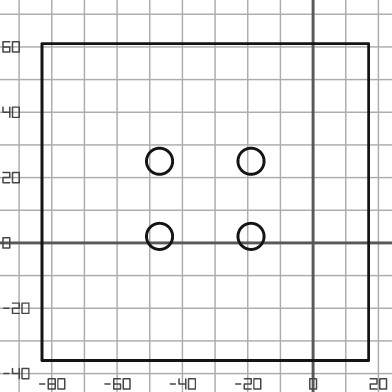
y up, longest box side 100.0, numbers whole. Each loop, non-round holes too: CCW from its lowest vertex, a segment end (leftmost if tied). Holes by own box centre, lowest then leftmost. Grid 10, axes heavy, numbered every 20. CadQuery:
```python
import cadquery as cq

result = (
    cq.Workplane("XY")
    .moveTo(-83.0, -36.0)
    .lineTo(17.0, -36.0)
    .lineTo(17.0, 61.0)
    .lineTo(-83.0, 61.0)
    .close()
    .moveTo(-47.0, 2.0)
    .circle(4.0)
    .moveTo(-19.0, 2.0)
    .circle(4.0)
    .moveTo(-47.0, 25.0)
    .circle(4.0)
    .moveTo(-19.0, 25.0)
    .circle(4.0)
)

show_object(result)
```